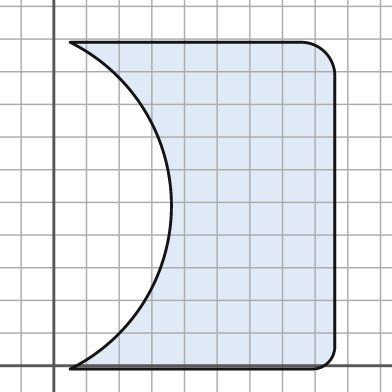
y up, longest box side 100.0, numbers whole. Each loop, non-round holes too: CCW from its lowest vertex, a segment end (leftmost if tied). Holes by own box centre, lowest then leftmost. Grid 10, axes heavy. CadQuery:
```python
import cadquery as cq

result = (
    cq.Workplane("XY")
    .moveTo(5.0, -1.0)
    .lineTo(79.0, -1.0)
    .threePointArc((84.0, 1.0), (86.0, 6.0))
    .lineTo(86.0, 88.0)
    .threePointArc((83.0, 96.0), (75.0, 99.0))
    .lineTo(5.0, 99.0)
    .threePointArc((36.0, 49.0), (5.0, -1.0))
    .close()
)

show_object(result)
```